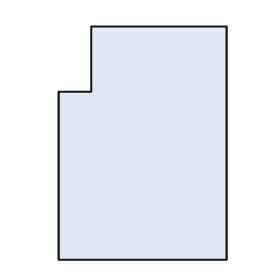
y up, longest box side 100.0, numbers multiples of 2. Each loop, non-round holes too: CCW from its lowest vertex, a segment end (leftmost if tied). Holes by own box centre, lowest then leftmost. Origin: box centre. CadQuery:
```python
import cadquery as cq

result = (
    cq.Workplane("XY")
    .moveTo(-36.0, -50.0)
    .lineTo(36.0, -50.0)
    .lineTo(36.0, 50.0)
    .lineTo(-22.0, 50.0)
    .lineTo(-22.0, 22.0)
    .lineTo(-36.0, 22.0)
    .close()
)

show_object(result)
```